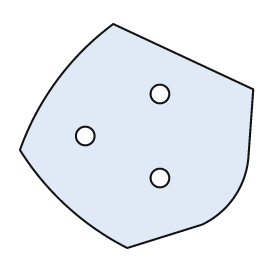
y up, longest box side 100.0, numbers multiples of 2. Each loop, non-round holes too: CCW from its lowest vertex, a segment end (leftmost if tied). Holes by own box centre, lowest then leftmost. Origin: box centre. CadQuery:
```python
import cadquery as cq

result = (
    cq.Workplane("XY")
    .moveTo(-4.0, -48.0)
    .lineTo(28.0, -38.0)
    .threePointArc((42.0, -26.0), (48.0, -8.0))
    .lineTo(50.0, 20.0)
    .lineTo(-10.0, 48.0)
    .threePointArc((-34.0, 24.0), (-50.0, -6.0))
    .threePointArc((-30.0, -30.0), (-4.0, -48.0))
    .close()
    .moveTo(10.0, -18.0)
    .circle(4.0)
    .moveTo(-22.0, 0.0)
    .circle(4.0)
    .moveTo(10.0, 18.0)
    .circle(4.0)
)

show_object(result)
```